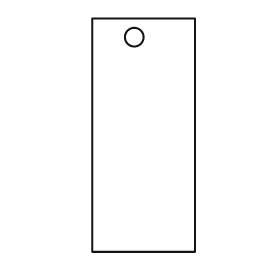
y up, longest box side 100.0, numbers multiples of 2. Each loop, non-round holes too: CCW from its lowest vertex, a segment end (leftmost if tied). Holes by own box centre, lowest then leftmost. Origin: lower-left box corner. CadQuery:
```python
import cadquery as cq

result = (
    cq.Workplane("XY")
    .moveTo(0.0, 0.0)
    .lineTo(44.0, 0.0)
    .lineTo(44.0, 100.0)
    .lineTo(0.0, 100.0)
    .close()
    .moveTo(18.0, 92.0)
    .circle(4.0)
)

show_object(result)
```